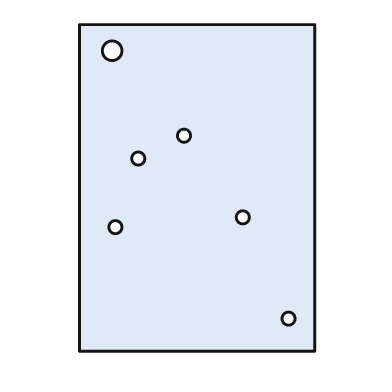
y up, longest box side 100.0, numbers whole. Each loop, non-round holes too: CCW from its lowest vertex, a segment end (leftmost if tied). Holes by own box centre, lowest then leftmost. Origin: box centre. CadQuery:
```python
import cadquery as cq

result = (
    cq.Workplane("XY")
    .moveTo(-36.0, -50.0)
    .lineTo(36.0, -50.0)
    .lineTo(36.0, 50.0)
    .lineTo(-36.0, 50.0)
    .close()
    .moveTo(28.0, -40.0)
    .circle(2.0)
    .moveTo(-25.0, -12.0)
    .circle(2.0)
    .moveTo(14.0, -9.0)
    .circle(2.0)
    .moveTo(-18.0, 9.0)
    .circle(2.0)
    .moveTo(-4.0, 16.0)
    .circle(2.0)
    .moveTo(-26.0, 42.0)
    .circle(3.0)
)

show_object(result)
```